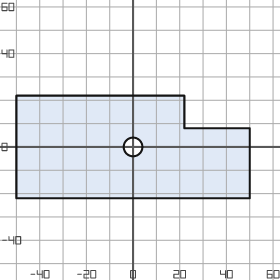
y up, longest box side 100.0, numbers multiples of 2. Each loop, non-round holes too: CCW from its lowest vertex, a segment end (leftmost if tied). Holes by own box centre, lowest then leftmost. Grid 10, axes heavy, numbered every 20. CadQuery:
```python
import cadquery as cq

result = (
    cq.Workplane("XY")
    .moveTo(-50.0, -22.0)
    .lineTo(50.0, -22.0)
    .lineTo(50.0, 8.0)
    .lineTo(22.0, 8.0)
    .lineTo(22.0, 22.0)
    .lineTo(-50.0, 22.0)
    .close()
    .moveTo(0.0, 0.0)
    .circle(4.0)
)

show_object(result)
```